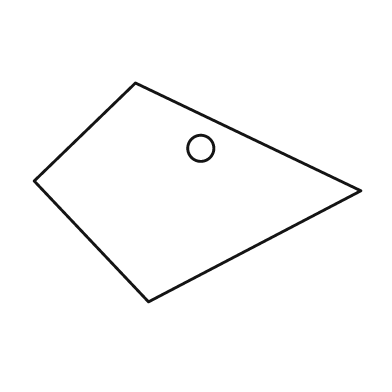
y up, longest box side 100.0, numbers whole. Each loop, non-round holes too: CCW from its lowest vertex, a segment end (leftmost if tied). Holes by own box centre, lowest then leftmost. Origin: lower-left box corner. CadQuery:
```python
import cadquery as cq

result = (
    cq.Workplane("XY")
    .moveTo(35.0, 0.0)
    .lineTo(100.0, 34.0)
    .lineTo(31.0, 67.0)
    .lineTo(0.0, 37.0)
    .close()
    .moveTo(51.0, 47.0)
    .circle(4.0)
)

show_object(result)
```